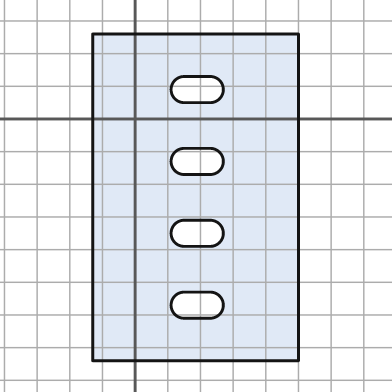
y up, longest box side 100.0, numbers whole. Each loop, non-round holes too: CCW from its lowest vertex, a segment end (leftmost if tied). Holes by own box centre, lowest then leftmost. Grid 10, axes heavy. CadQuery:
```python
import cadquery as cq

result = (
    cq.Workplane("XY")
    .moveTo(-13.0, -74.0)
    .lineTo(50.0, -74.0)
    .lineTo(50.0, 26.0)
    .lineTo(-13.0, 26.0)
    .close()
    .moveTo(15.0, -61.0)
    .lineTo(23.0, -61.0)
    .threePointArc((27.0, -57.0), (23.0, -53.0))
    .lineTo(15.0, -53.0)
    .threePointArc((11.0, -57.0), (15.0, -61.0))
    .close()
    .moveTo(15.0, -39.0)
    .lineTo(23.0, -39.0)
    .threePointArc((27.0, -35.0), (23.0, -31.0))
    .lineTo(15.0, -31.0)
    .threePointArc((11.0, -35.0), (15.0, -39.0))
    .close()
    .moveTo(15.0, -17.0)
    .lineTo(23.0, -17.0)
    .threePointArc((27.0, -13.0), (23.0, -9.0))
    .lineTo(15.0, -9.0)
    .threePointArc((11.0, -13.0), (15.0, -17.0))
    .close()
    .moveTo(15.0, 5.0)
    .lineTo(23.0, 5.0)
    .threePointArc((27.0, 9.0), (23.0, 13.0))
    .lineTo(15.0, 13.0)
    .threePointArc((11.0, 9.0), (15.0, 5.0))
    .close()
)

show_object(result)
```